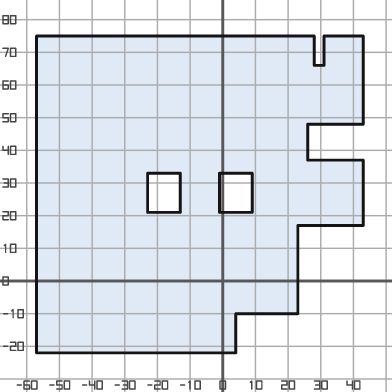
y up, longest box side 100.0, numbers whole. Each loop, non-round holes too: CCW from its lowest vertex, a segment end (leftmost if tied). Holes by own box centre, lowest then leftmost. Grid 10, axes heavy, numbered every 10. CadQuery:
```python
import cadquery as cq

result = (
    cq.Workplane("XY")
    .moveTo(-57.0, -22.0)
    .lineTo(4.0, -22.0)
    .lineTo(4.0, -10.0)
    .lineTo(23.0, -10.0)
    .lineTo(23.0, 17.0)
    .lineTo(43.0, 17.0)
    .lineTo(43.0, 37.0)
    .lineTo(26.0, 37.0)
    .lineTo(26.0, 48.0)
    .lineTo(43.0, 48.0)
    .lineTo(43.0, 75.0)
    .lineTo(31.0, 75.0)
    .lineTo(31.0, 66.0)
    .lineTo(28.0, 66.0)
    .lineTo(28.0, 75.0)
    .lineTo(-57.0, 75.0)
    .close()
    .moveTo(-23.0, 21.0)
    .lineTo(-13.0, 21.0)
    .lineTo(-13.0, 33.0)
    .lineTo(-23.0, 33.0)
    .close()
    .moveTo(-1.0, 21.0)
    .lineTo(9.0, 21.0)
    .lineTo(9.0, 33.0)
    .lineTo(-1.0, 33.0)
    .close()
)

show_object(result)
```